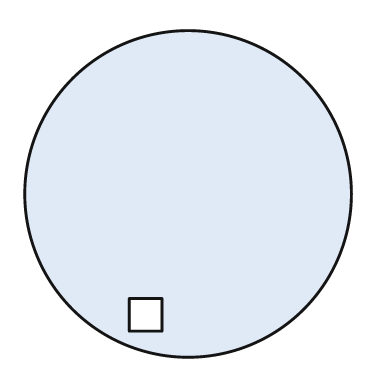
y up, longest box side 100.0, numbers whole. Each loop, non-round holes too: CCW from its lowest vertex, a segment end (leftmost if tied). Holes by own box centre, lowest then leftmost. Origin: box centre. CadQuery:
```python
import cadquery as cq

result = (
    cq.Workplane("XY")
    .moveTo(0.0, 0.0)
    .circle(50.0)
    .moveTo(-18.0, -42.0)
    .lineTo(-8.0, -42.0)
    .lineTo(-8.0, -32.0)
    .lineTo(-18.0, -32.0)
    .close()
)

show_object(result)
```